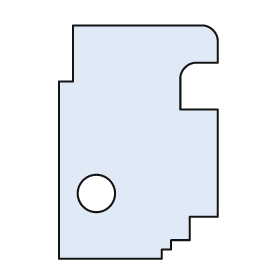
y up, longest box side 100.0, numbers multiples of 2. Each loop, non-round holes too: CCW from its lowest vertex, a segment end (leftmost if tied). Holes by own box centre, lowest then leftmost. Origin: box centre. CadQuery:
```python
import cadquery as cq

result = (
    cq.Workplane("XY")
    .moveTo(-34.0, -50.0)
    .lineTo(10.0, -50.0)
    .lineTo(10.0, -46.0)
    .lineTo(14.0, -46.0)
    .lineTo(14.0, -42.0)
    .lineTo(22.0, -42.0)
    .lineTo(22.0, -32.0)
    .lineTo(34.0, -32.0)
    .lineTo(34.0, 14.0)
    .lineTo(18.0, 14.0)
    .lineTo(18.0, 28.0)
    .threePointArc((20.0, 32.0), (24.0, 34.0))
    .lineTo(34.0, 34.0)
    .lineTo(34.0, 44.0)
    .threePointArc((32.0, 48.0), (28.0, 50.0))
    .lineTo(-28.0, 50.0)
    .lineTo(-28.0, 26.0)
    .lineTo(-34.0, 26.0)
    .close()
    .moveTo(-18.0, -22.0)
    .circle(8.0)
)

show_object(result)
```